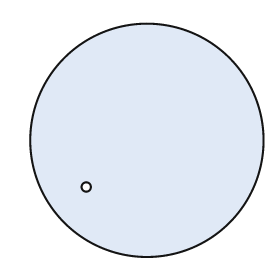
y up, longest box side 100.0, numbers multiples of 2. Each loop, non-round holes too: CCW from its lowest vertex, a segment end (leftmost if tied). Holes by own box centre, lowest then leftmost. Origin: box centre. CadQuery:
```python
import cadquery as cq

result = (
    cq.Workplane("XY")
    .moveTo(0.0, 0.0)
    .circle(50.0)
    .moveTo(-26.0, -20.0)
    .circle(2.0)
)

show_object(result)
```